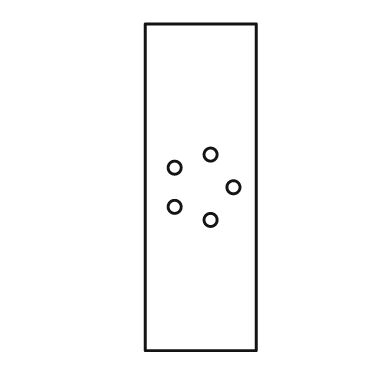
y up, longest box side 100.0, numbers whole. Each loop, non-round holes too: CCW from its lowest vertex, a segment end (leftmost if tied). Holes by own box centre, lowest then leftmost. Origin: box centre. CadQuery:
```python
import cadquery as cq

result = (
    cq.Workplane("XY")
    .moveTo(-17.0, -50.0)
    .lineTo(17.0, -50.0)
    .lineTo(17.0, 50.0)
    .lineTo(-17.0, 50.0)
    .close()
    .moveTo(3.0, -10.0)
    .circle(2.0)
    .moveTo(-8.0, -6.0)
    .circle(2.0)
    .moveTo(10.0, 0.0)
    .circle(2.0)
    .moveTo(-8.0, 6.0)
    .circle(2.0)
    .moveTo(3.0, 10.0)
    .circle(2.0)
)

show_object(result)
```